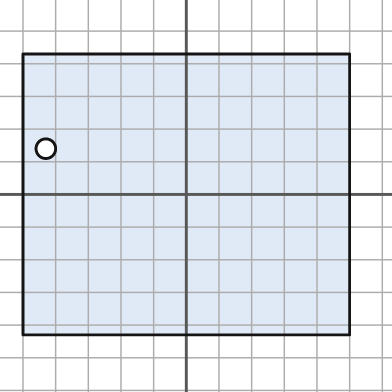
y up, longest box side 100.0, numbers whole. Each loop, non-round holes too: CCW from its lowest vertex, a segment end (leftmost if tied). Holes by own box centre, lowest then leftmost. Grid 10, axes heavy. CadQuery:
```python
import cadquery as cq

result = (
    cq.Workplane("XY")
    .moveTo(-50.0, -43.0)
    .lineTo(50.0, -43.0)
    .lineTo(50.0, 43.0)
    .lineTo(-50.0, 43.0)
    .close()
    .moveTo(-43.0, 14.0)
    .circle(3.0)
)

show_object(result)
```